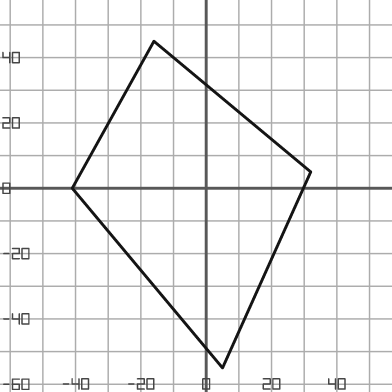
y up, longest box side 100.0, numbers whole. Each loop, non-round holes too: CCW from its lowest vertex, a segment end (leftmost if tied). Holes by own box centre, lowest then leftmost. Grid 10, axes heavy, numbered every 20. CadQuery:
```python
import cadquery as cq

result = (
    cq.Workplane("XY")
    .moveTo(5.0, -55.0)
    .lineTo(32.0, 5.0)
    .lineTo(-16.0, 45.0)
    .lineTo(-41.0, 0.0)
    .close()
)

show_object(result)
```